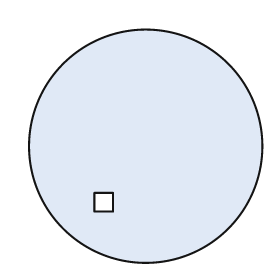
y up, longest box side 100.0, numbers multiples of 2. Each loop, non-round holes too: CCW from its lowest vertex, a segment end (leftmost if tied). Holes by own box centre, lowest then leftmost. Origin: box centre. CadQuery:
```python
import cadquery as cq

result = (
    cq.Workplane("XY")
    .moveTo(0.0, 0.0)
    .circle(50.0)
    .moveTo(-22.0, -28.0)
    .lineTo(-14.0, -28.0)
    .lineTo(-14.0, -20.0)
    .lineTo(-22.0, -20.0)
    .close()
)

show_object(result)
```